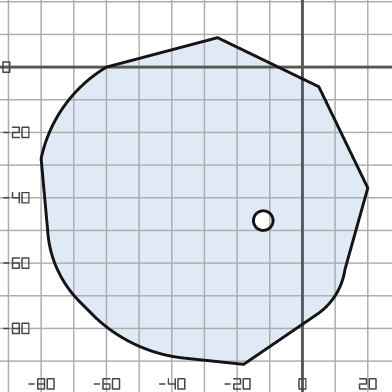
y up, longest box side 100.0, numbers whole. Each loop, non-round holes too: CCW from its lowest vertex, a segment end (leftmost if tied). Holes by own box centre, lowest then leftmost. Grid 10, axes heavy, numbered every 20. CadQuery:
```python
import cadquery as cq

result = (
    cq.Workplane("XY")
    .moveTo(-18.0, -91.0)
    .lineTo(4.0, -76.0)
    .threePointArc((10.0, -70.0), (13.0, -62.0))
    .lineTo(20.0, -37.0)
    .lineTo(5.0, -6.0)
    .lineTo(-26.0, 9.0)
    .lineTo(-60.0, 0.0)
    .threePointArc((-73.0, -12.0), (-80.0, -28.0))
    .lineTo(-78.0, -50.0)
    .threePointArc((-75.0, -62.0), (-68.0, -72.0))
    .lineTo(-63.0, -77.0)
    .threePointArc((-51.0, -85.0), (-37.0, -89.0))
    .close()
    .moveTo(-12.0, -47.0)
    .circle(3.0)
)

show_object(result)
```